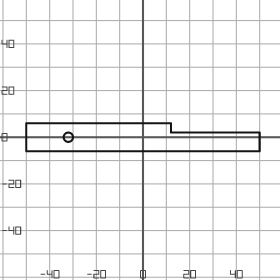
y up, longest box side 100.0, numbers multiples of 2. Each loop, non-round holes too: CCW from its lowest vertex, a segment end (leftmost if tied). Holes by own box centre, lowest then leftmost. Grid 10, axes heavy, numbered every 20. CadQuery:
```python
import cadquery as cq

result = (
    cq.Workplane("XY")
    .moveTo(-50.0, -6.0)
    .lineTo(50.0, -6.0)
    .lineTo(50.0, 2.0)
    .lineTo(12.0, 2.0)
    .lineTo(12.0, 6.0)
    .lineTo(-50.0, 6.0)
    .close()
    .moveTo(-32.0, 0.0)
    .circle(2.0)
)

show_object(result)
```